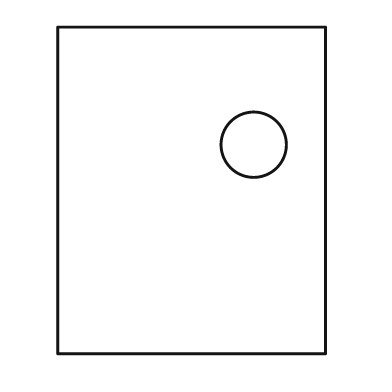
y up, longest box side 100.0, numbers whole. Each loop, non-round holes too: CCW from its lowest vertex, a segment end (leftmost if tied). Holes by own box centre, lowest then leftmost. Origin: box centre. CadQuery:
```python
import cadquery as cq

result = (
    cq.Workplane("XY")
    .moveTo(-41.0, -50.0)
    .lineTo(41.0, -50.0)
    .lineTo(41.0, 50.0)
    .lineTo(-41.0, 50.0)
    .close()
    .moveTo(19.0, 14.0)
    .circle(10.0)
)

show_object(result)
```